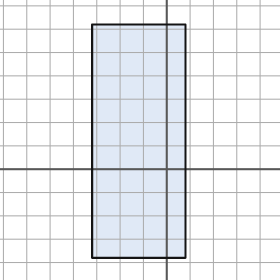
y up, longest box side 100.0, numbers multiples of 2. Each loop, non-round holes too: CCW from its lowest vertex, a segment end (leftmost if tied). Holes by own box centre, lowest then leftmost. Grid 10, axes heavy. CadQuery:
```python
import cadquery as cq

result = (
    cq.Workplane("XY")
    .moveTo(-32.0, -38.0)
    .lineTo(8.0, -38.0)
    .lineTo(8.0, 62.0)
    .lineTo(-32.0, 62.0)
    .close()
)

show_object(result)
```